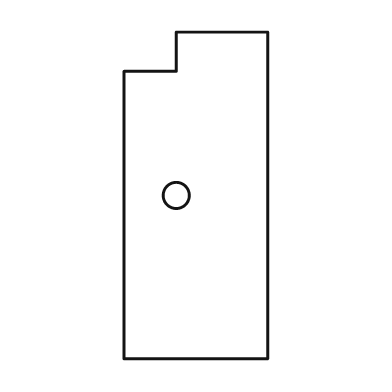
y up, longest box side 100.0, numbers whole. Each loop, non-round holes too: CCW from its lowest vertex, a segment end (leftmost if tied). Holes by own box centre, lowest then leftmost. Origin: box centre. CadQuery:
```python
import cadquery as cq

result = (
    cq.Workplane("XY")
    .moveTo(-22.0, -50.0)
    .lineTo(22.0, -50.0)
    .lineTo(22.0, 50.0)
    .lineTo(-6.0, 50.0)
    .lineTo(-6.0, 38.0)
    .lineTo(-22.0, 38.0)
    .close()
    .moveTo(-6.0, 0.0)
    .circle(4.0)
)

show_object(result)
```